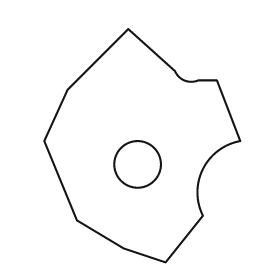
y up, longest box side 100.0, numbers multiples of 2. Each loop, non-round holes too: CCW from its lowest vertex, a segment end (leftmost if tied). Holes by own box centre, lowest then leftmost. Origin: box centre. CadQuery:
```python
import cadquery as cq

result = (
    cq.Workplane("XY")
    .moveTo(10.0, -50.0)
    .lineTo(26.0, -30.0)
    .threePointArc((26.0, -10.0), (42.0, 2.0))
    .lineTo(32.0, 28.0)
    .lineTo(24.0, 28.0)
    .threePointArc((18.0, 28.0), (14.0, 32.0))
    .lineTo(-6.0, 50.0)
    .lineTo(-32.0, 24.0)
    .lineTo(-42.0, 2.0)
    .lineTo(-28.0, -32.0)
    .lineTo(-8.0, -44.0)
    .close()
    .moveTo(-2.0, -8.0)
    .circle(10.0)
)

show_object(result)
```